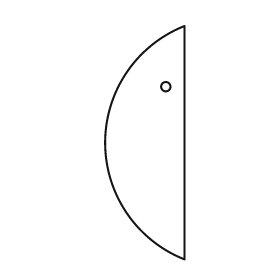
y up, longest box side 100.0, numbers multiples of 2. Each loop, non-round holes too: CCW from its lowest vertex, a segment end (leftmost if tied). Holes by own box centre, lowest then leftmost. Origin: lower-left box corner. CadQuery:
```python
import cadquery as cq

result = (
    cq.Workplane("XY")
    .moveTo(34.0, 0.0)
    .lineTo(34.0, 100.0)
    .threePointArc((0.0, 50.0), (34.0, 0.0))
    .close()
    .moveTo(26.0, 74.0)
    .circle(2.0)
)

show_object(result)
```